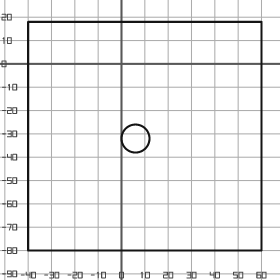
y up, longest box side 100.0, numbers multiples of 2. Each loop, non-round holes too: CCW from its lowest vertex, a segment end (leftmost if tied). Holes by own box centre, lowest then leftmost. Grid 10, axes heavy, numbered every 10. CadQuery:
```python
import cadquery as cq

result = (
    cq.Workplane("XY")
    .moveTo(-40.0, -80.0)
    .lineTo(60.0, -80.0)
    .lineTo(60.0, 18.0)
    .lineTo(-40.0, 18.0)
    .close()
    .moveTo(6.0, -32.0)
    .circle(6.0)
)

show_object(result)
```